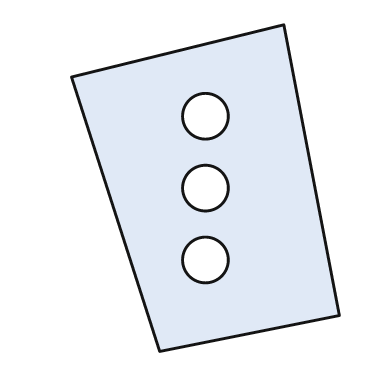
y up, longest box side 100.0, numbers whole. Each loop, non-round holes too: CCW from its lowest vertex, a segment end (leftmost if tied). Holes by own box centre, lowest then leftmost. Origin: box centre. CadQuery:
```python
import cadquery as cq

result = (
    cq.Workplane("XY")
    .moveTo(-14.0, -50.0)
    .lineTo(41.0, -39.0)
    .lineTo(24.0, 50.0)
    .lineTo(-41.0, 34.0)
    .close()
    .moveTo(0.0, -22.0)
    .circle(7.0)
    .moveTo(0.0, 0.0)
    .circle(7.0)
    .moveTo(0.0, 22.0)
    .circle(7.0)
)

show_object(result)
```